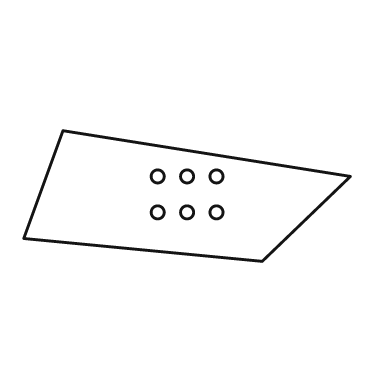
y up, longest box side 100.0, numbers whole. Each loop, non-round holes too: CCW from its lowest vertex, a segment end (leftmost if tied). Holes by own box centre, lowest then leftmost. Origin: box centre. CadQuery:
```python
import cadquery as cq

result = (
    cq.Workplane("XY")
    .moveTo(23.0, -20.0)
    .lineTo(50.0, 6.0)
    .lineTo(-38.0, 20.0)
    .lineTo(-50.0, -13.0)
    .close()
    .moveTo(-9.0, -5.0)
    .circle(2.0)
    .moveTo(0.0, -5.0)
    .circle(2.0)
    .moveTo(9.0, -5.0)
    .circle(2.0)
    .moveTo(-9.0, 6.0)
    .circle(2.0)
    .moveTo(0.0, 6.0)
    .circle(2.0)
    .moveTo(9.0, 6.0)
    .circle(2.0)
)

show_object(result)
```